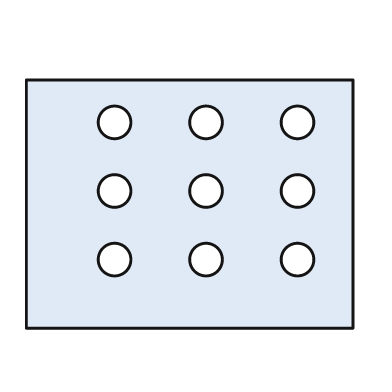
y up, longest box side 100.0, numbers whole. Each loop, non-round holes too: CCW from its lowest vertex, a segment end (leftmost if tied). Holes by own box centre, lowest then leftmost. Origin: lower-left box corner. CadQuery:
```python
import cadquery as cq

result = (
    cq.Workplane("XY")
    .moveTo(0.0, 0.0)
    .lineTo(100.0, 0.0)
    .lineTo(100.0, 76.0)
    .lineTo(0.0, 76.0)
    .close()
    .moveTo(27.0, 21.0)
    .circle(5.0)
    .moveTo(55.0, 21.0)
    .circle(5.0)
    .moveTo(83.0, 21.0)
    .circle(5.0)
    .moveTo(27.0, 42.0)
    .circle(5.0)
    .moveTo(55.0, 42.0)
    .circle(5.0)
    .moveTo(83.0, 42.0)
    .circle(5.0)
    .moveTo(27.0, 63.0)
    .circle(5.0)
    .moveTo(55.0, 63.0)
    .circle(5.0)
    .moveTo(83.0, 63.0)
    .circle(5.0)
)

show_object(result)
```